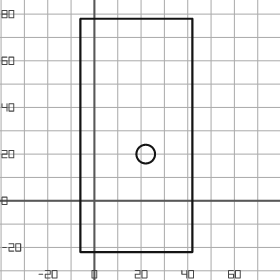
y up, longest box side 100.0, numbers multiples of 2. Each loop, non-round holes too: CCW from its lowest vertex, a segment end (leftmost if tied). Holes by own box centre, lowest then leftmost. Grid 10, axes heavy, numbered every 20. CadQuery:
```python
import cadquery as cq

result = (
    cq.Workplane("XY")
    .moveTo(-6.0, -22.0)
    .lineTo(42.0, -22.0)
    .lineTo(42.0, 78.0)
    .lineTo(-6.0, 78.0)
    .close()
    .moveTo(22.0, 20.0)
    .circle(4.0)
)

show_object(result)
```